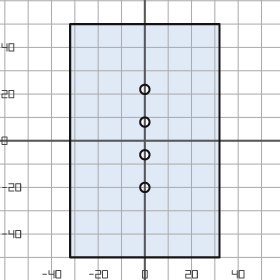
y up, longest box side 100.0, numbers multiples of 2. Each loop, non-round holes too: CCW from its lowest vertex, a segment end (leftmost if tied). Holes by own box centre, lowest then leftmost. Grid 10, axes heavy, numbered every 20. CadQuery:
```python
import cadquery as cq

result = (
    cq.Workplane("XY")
    .moveTo(-32.0, -50.0)
    .lineTo(32.0, -50.0)
    .lineTo(32.0, 50.0)
    .lineTo(-32.0, 50.0)
    .close()
    .moveTo(0.0, -20.0)
    .circle(2.0)
    .moveTo(0.0, -6.0)
    .circle(2.0)
    .moveTo(0.0, 8.0)
    .circle(2.0)
    .moveTo(0.0, 22.0)
    .circle(2.0)
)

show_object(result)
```